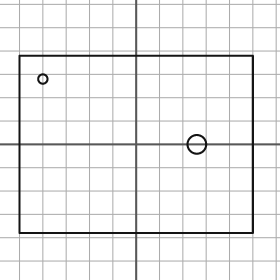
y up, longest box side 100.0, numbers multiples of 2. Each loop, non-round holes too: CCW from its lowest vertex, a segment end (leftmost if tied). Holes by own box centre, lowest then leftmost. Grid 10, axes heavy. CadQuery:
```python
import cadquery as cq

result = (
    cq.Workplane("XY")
    .moveTo(-50.0, -38.0)
    .lineTo(50.0, -38.0)
    .lineTo(50.0, 38.0)
    .lineTo(-50.0, 38.0)
    .close()
    .moveTo(26.0, 0.0)
    .circle(4.0)
    .moveTo(-40.0, 28.0)
    .circle(2.0)
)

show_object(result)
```